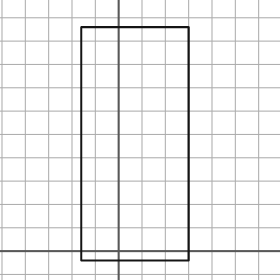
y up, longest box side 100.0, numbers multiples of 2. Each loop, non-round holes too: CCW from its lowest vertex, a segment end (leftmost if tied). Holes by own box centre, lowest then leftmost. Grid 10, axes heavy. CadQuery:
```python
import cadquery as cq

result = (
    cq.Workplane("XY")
    .moveTo(-16.0, -4.0)
    .lineTo(30.0, -4.0)
    .lineTo(30.0, 96.0)
    .lineTo(-16.0, 96.0)
    .close()
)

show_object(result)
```